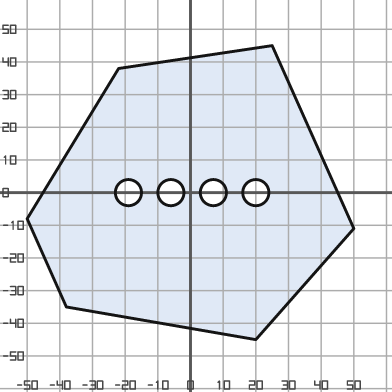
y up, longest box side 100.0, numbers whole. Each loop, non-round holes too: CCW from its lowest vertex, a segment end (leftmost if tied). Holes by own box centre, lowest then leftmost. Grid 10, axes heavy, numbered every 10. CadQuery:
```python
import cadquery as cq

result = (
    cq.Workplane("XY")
    .moveTo(20.0, -45.0)
    .lineTo(50.0, -11.0)
    .lineTo(25.0, 45.0)
    .lineTo(-22.0, 38.0)
    .lineTo(-50.0, -8.0)
    .lineTo(-38.0, -35.0)
    .close()
    .moveTo(-19.0, 0.0)
    .circle(4.0)
    .moveTo(-6.0, 0.0)
    .circle(4.0)
    .moveTo(7.0, 0.0)
    .circle(4.0)
    .moveTo(20.0, 0.0)
    .circle(4.0)
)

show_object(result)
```